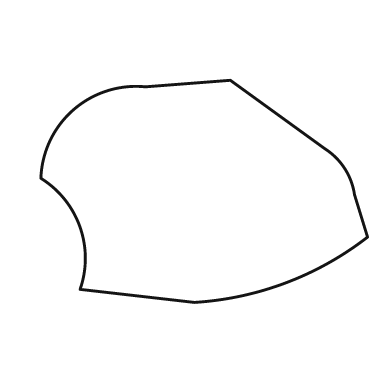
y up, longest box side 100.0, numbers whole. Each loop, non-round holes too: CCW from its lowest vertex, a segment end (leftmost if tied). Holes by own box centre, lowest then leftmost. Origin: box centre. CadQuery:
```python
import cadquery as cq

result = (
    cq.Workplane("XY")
    .moveTo(-3.0, -34.0)
    .threePointArc((25.0, -28.0), (50.0, -14.0))
    .lineTo(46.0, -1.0)
    .threePointArc((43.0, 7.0), (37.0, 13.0))
    .lineTo(8.0, 34.0)
    .lineTo(-18.0, 32.0)
    .threePointArc((-40.0, 25.0), (-50.0, 4.0))
    .threePointArc((-38.0, -11.0), (-38.0, -30.0))
    .close()
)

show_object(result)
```